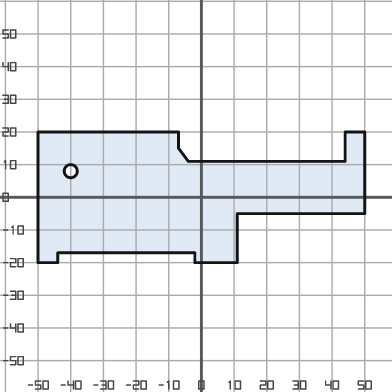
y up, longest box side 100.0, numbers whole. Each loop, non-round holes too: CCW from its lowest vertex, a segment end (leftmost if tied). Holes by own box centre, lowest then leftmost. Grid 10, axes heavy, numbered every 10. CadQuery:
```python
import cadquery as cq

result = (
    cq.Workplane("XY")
    .moveTo(-50.0, -20.0)
    .lineTo(-44.0, -20.0)
    .lineTo(-44.0, -17.0)
    .lineTo(-2.0, -17.0)
    .lineTo(-2.0, -20.0)
    .lineTo(11.0, -20.0)
    .lineTo(11.0, -5.0)
    .lineTo(50.0, -5.0)
    .lineTo(50.0, 20.0)
    .lineTo(44.0, 20.0)
    .lineTo(44.0, 11.0)
    .lineTo(-4.0, 11.0)
    .lineTo(-7.0, 15.0)
    .lineTo(-7.0, 20.0)
    .lineTo(-50.0, 20.0)
    .close()
    .moveTo(-40.0, 8.0)
    .circle(2.0)
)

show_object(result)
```